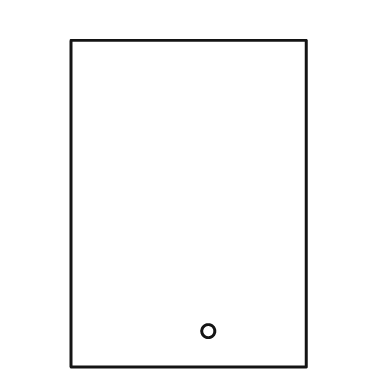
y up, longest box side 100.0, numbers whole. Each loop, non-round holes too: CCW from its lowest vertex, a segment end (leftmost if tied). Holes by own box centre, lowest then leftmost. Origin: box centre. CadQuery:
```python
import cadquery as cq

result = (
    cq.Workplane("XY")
    .moveTo(-36.0, -50.0)
    .lineTo(36.0, -50.0)
    .lineTo(36.0, 50.0)
    .lineTo(-36.0, 50.0)
    .close()
    .moveTo(6.0, -39.0)
    .circle(2.0)
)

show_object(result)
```